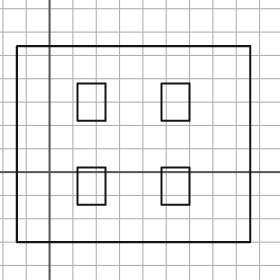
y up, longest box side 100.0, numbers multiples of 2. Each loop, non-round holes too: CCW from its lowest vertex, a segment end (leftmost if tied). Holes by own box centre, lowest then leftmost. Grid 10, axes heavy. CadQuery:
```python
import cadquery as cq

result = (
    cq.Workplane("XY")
    .moveTo(-14.0, -30.0)
    .lineTo(86.0, -30.0)
    .lineTo(86.0, 54.0)
    .lineTo(-14.0, 54.0)
    .close()
    .moveTo(12.0, -14.0)
    .lineTo(24.0, -14.0)
    .lineTo(24.0, 2.0)
    .lineTo(12.0, 2.0)
    .close()
    .moveTo(48.0, -14.0)
    .lineTo(60.0, -14.0)
    .lineTo(60.0, 2.0)
    .lineTo(48.0, 2.0)
    .close()
    .moveTo(12.0, 22.0)
    .lineTo(24.0, 22.0)
    .lineTo(24.0, 38.0)
    .lineTo(12.0, 38.0)
    .close()
    .moveTo(48.0, 22.0)
    .lineTo(60.0, 22.0)
    .lineTo(60.0, 38.0)
    .lineTo(48.0, 38.0)
    .close()
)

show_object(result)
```